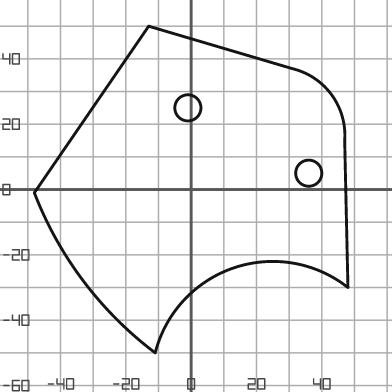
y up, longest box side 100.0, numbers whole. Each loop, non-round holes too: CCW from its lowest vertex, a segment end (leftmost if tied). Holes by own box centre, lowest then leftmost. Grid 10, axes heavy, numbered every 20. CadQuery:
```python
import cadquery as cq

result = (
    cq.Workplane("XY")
    .moveTo(-11.0, -50.0)
    .threePointArc((13.0, -24.0), (48.0, -30.0))
    .lineTo(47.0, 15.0)
    .threePointArc((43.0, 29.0), (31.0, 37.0))
    .lineTo(-13.0, 50.0)
    .lineTo(-48.0, -1.0)
    .threePointArc((-33.0, -28.0), (-11.0, -50.0))
    .close()
    .moveTo(36.0, 5.0)
    .circle(4.0)
    .moveTo(-1.0, 25.0)
    .circle(4.0)
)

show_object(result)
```